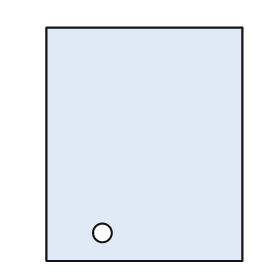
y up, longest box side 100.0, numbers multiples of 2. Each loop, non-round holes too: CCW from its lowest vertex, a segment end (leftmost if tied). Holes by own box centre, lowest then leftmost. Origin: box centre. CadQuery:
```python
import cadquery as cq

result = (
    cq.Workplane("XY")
    .moveTo(-42.0, -50.0)
    .lineTo(42.0, -50.0)
    .lineTo(42.0, 50.0)
    .lineTo(-42.0, 50.0)
    .close()
    .moveTo(-18.0, -38.0)
    .circle(4.0)
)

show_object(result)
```